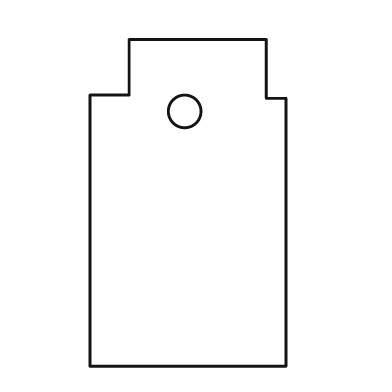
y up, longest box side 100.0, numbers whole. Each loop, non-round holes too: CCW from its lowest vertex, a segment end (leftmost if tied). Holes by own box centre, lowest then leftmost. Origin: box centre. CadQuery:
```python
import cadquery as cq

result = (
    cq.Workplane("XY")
    .moveTo(-30.0, -50.0)
    .lineTo(30.0, -50.0)
    .lineTo(30.0, 32.0)
    .lineTo(24.0, 32.0)
    .lineTo(24.0, 50.0)
    .lineTo(-18.0, 50.0)
    .lineTo(-18.0, 33.0)
    .lineTo(-30.0, 33.0)
    .close()
    .moveTo(-1.0, 28.0)
    .circle(5.0)
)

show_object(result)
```